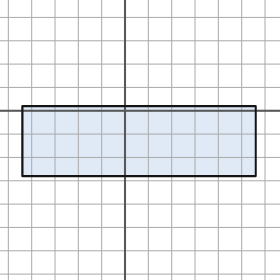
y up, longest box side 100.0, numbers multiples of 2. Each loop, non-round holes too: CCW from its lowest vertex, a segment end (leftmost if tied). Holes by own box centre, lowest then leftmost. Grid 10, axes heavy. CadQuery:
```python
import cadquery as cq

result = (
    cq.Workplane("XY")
    .moveTo(-44.0, -28.0)
    .lineTo(56.0, -28.0)
    .lineTo(56.0, 2.0)
    .lineTo(-44.0, 2.0)
    .close()
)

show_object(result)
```